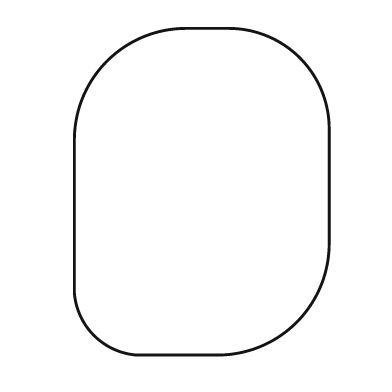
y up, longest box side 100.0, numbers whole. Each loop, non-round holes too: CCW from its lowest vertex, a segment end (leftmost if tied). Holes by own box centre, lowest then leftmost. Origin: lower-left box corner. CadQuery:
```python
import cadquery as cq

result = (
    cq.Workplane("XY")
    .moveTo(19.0, 0.0)
    .lineTo(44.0, 0.0)
    .threePointArc((68.0, 10.0), (78.0, 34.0))
    .lineTo(78.0, 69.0)
    .threePointArc((69.0, 91.0), (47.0, 100.0))
    .lineTo(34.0, 100.0)
    .threePointArc((10.0, 90.0), (0.0, 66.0))
    .lineTo(0.0, 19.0)
    .threePointArc((6.0, 6.0), (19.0, 0.0))
    .close()
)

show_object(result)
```